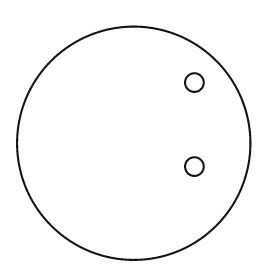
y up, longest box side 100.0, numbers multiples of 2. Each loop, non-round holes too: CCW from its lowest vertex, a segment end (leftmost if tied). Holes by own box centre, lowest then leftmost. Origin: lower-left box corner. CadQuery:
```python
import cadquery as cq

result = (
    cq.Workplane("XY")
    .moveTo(50.0, 50.0)
    .circle(50.0)
    .moveTo(76.0, 40.0)
    .circle(4.0)
    .moveTo(76.0, 76.0)
    .circle(4.0)
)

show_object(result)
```